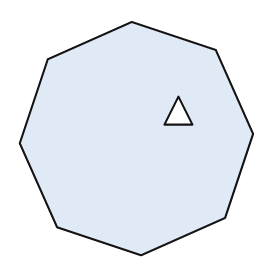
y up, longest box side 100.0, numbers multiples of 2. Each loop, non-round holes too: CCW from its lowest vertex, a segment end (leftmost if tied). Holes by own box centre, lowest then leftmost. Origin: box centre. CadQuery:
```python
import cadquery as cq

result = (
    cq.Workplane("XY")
    .moveTo(2.0, -50.0)
    .lineTo(38.0, -34.0)
    .lineTo(50.0, 2.0)
    .lineTo(34.0, 38.0)
    .lineTo(-2.0, 50.0)
    .lineTo(-38.0, 34.0)
    .lineTo(-50.0, -2.0)
    .lineTo(-34.0, -38.0)
    .close()
    .moveTo(12.0, 6.0)
    .lineTo(24.0, 6.0)
    .lineTo(18.0, 18.0)
    .close()
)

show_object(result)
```